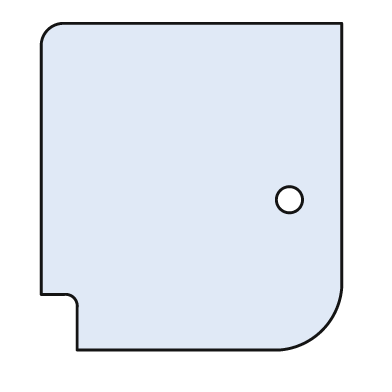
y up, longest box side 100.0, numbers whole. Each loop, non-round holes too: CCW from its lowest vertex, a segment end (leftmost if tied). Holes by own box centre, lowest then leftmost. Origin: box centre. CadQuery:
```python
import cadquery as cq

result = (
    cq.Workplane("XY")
    .moveTo(-35.0, -50.0)
    .lineTo(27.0, -50.0)
    .threePointArc((40.0, -44.0), (46.0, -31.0))
    .lineTo(46.0, 50.0)
    .lineTo(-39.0, 50.0)
    .threePointArc((-44.0, 48.0), (-46.0, 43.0))
    .lineTo(-46.0, -33.0)
    .lineTo(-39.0, -33.0)
    .threePointArc((-36.0, -34.0), (-35.0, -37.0))
    .close()
    .moveTo(30.0, -4.0)
    .circle(4.0)
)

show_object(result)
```